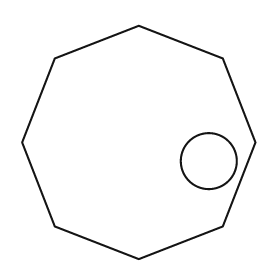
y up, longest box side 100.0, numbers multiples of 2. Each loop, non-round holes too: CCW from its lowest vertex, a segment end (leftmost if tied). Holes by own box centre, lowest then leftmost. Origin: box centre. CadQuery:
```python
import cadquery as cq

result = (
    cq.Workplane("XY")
    .moveTo(0.0, -50.0)
    .lineTo(36.0, -36.0)
    .lineTo(50.0, 0.0)
    .lineTo(36.0, 36.0)
    .lineTo(0.0, 50.0)
    .lineTo(-36.0, 36.0)
    .lineTo(-50.0, 0.0)
    .lineTo(-36.0, -36.0)
    .close()
    .moveTo(30.0, -8.0)
    .circle(12.0)
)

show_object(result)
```